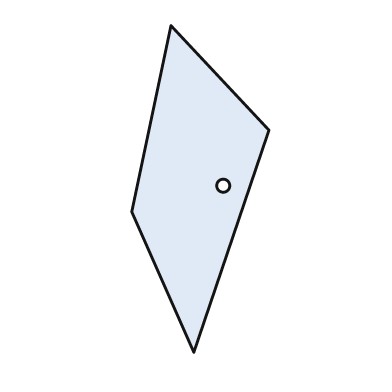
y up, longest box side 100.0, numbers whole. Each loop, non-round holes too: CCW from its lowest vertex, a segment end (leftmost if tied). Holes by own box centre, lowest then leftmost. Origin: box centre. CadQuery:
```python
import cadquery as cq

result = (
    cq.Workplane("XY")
    .moveTo(-2.0, -50.0)
    .lineTo(21.0, 18.0)
    .lineTo(-9.0, 50.0)
    .lineTo(-21.0, -7.0)
    .close()
    .moveTo(7.0, 1.0)
    .circle(2.0)
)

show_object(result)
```